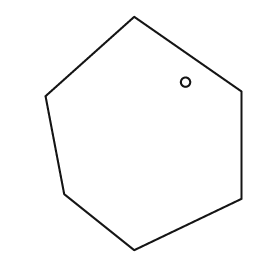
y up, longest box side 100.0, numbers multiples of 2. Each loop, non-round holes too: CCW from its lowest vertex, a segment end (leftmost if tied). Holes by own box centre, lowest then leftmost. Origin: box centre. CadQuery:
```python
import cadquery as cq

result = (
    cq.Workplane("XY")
    .moveTo(-4.0, -50.0)
    .lineTo(42.0, -28.0)
    .lineTo(42.0, 18.0)
    .lineTo(-4.0, 50.0)
    .lineTo(-42.0, 16.0)
    .lineTo(-34.0, -26.0)
    .close()
    .moveTo(18.0, 22.0)
    .circle(2.0)
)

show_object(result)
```